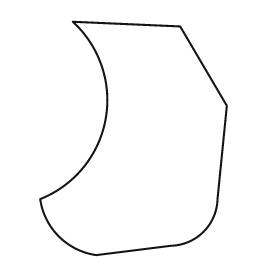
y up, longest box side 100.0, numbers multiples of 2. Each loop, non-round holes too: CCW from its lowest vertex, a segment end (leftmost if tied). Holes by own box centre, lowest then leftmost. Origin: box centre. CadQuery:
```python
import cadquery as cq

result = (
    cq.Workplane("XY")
    .moveTo(-16.0, -50.0)
    .lineTo(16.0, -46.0)
    .threePointArc((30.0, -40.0), (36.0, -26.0))
    .lineTo(40.0, 14.0)
    .lineTo(20.0, 48.0)
    .lineTo(-26.0, 50.0)
    .threePointArc((-12.0, 8.0), (-40.0, -26.0))
    .threePointArc((-32.0, -42.0), (-16.0, -50.0))
    .close()
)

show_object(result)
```